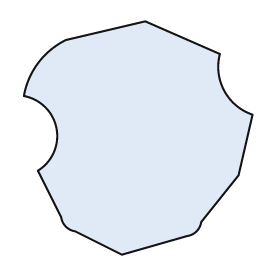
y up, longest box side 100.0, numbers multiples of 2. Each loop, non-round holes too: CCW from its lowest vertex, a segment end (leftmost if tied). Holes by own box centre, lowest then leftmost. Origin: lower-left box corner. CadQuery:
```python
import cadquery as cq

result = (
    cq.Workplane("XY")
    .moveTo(42.0, 0.0)
    .lineTo(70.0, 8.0)
    .threePointArc((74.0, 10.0), (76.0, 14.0))
    .lineTo(92.0, 34.0)
    .lineTo(98.0, 60.0)
    .threePointArc((86.0, 70.0), (84.0, 86.0))
    .lineTo(52.0, 100.0)
    .lineTo(18.0, 92.0)
    .threePointArc((6.0, 82.0), (0.0, 68.0))
    .threePointArc((14.0, 54.0), (6.0, 36.0))
    .lineTo(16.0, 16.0)
    .threePointArc((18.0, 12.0), (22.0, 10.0))
    .close()
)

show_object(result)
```